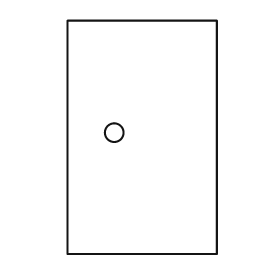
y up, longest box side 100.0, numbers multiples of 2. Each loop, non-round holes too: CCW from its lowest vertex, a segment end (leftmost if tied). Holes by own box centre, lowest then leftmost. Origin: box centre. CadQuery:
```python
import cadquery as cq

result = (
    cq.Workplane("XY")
    .moveTo(-32.0, -50.0)
    .lineTo(32.0, -50.0)
    .lineTo(32.0, 50.0)
    .lineTo(-32.0, 50.0)
    .close()
    .moveTo(-12.0, 2.0)
    .circle(4.0)
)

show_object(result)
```